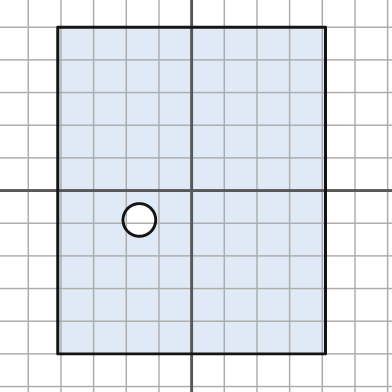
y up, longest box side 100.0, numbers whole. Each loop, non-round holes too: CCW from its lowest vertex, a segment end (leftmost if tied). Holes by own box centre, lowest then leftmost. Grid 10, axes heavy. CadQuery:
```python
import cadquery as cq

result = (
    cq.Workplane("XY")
    .moveTo(-41.0, -50.0)
    .lineTo(41.0, -50.0)
    .lineTo(41.0, 50.0)
    .lineTo(-41.0, 50.0)
    .close()
    .moveTo(-16.0, -9.0)
    .circle(5.0)
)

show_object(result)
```